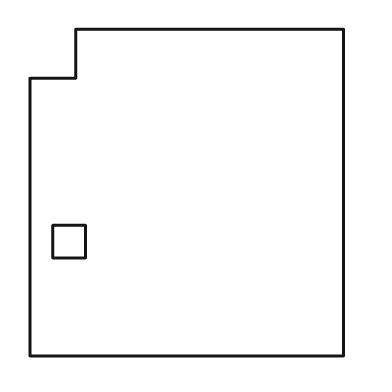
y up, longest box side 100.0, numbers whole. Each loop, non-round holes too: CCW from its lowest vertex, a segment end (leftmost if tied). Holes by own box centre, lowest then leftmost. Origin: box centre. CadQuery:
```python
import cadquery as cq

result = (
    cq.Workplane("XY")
    .moveTo(-48.0, -50.0)
    .lineTo(48.0, -50.0)
    .lineTo(48.0, 50.0)
    .lineTo(-34.0, 50.0)
    .lineTo(-34.0, 35.0)
    .lineTo(-48.0, 35.0)
    .close()
    .moveTo(-41.0, -20.0)
    .lineTo(-31.0, -20.0)
    .lineTo(-31.0, -10.0)
    .lineTo(-41.0, -10.0)
    .close()
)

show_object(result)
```